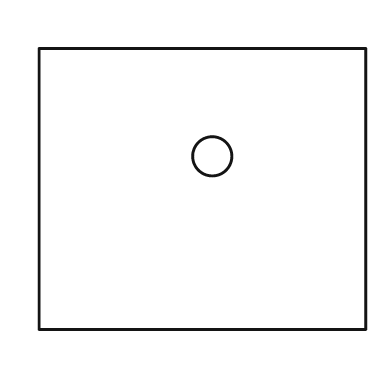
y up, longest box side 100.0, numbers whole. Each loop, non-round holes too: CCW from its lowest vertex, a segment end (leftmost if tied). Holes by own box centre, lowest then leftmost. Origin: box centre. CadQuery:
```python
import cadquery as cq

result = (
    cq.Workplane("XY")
    .moveTo(-50.0, -43.0)
    .lineTo(50.0, -43.0)
    .lineTo(50.0, 43.0)
    .lineTo(-50.0, 43.0)
    .close()
    .moveTo(3.0, 10.0)
    .circle(6.0)
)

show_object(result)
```